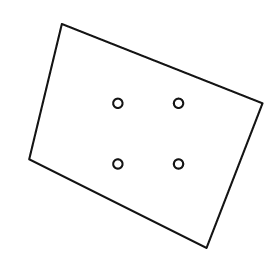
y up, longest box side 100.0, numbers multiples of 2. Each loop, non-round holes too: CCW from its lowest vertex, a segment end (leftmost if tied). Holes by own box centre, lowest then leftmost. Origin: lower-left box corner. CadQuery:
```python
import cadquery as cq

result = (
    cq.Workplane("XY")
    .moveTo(76.0, 0.0)
    .lineTo(100.0, 62.0)
    .lineTo(14.0, 96.0)
    .lineTo(0.0, 38.0)
    .close()
    .moveTo(38.0, 36.0)
    .circle(2.0)
    .moveTo(64.0, 36.0)
    .circle(2.0)
    .moveTo(38.0, 62.0)
    .circle(2.0)
    .moveTo(64.0, 62.0)
    .circle(2.0)
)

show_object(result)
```